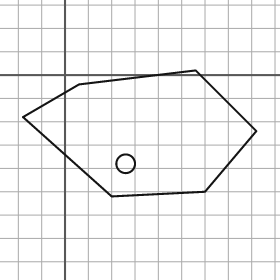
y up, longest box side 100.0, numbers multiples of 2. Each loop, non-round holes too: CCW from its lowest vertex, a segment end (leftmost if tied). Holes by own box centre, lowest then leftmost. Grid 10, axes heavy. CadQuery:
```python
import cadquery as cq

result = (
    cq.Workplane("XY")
    .moveTo(20.0, -52.0)
    .lineTo(60.0, -50.0)
    .lineTo(82.0, -24.0)
    .lineTo(56.0, 2.0)
    .lineTo(6.0, -4.0)
    .lineTo(-18.0, -18.0)
    .close()
    .moveTo(26.0, -38.0)
    .circle(4.0)
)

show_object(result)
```